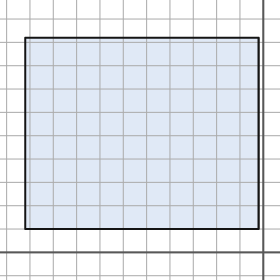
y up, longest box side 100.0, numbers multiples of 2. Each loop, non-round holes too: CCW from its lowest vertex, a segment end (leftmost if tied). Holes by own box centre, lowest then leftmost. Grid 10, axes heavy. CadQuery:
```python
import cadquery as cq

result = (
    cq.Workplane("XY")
    .moveTo(-102.0, 10.0)
    .lineTo(-2.0, 10.0)
    .lineTo(-2.0, 92.0)
    .lineTo(-102.0, 92.0)
    .close()
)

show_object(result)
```